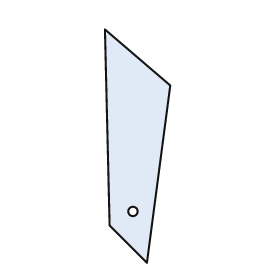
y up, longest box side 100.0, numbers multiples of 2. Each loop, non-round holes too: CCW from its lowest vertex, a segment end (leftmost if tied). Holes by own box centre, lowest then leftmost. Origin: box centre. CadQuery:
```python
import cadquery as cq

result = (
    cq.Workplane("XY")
    .moveTo(4.0, -50.0)
    .lineTo(14.0, 26.0)
    .lineTo(-14.0, 50.0)
    .lineTo(-12.0, -34.0)
    .close()
    .moveTo(-2.0, -28.0)
    .circle(2.0)
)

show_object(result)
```